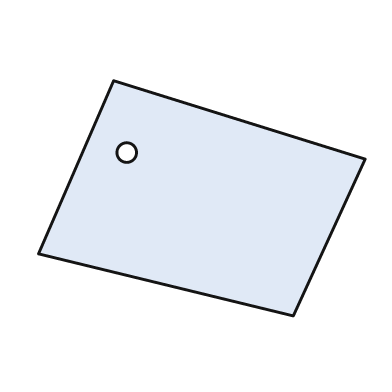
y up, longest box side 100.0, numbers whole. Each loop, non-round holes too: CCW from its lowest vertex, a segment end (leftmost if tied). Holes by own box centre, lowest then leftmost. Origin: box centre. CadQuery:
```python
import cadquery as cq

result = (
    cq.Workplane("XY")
    .moveTo(28.0, -36.0)
    .lineTo(50.0, 12.0)
    .lineTo(-27.0, 36.0)
    .lineTo(-50.0, -17.0)
    .close()
    .moveTo(-23.0, 14.0)
    .circle(3.0)
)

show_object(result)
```